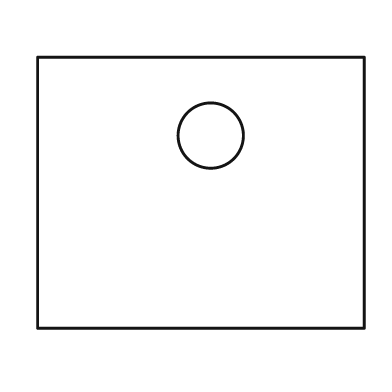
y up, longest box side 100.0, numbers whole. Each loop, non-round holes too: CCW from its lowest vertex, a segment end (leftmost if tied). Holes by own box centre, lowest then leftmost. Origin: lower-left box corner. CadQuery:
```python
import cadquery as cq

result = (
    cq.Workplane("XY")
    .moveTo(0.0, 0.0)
    .lineTo(100.0, 0.0)
    .lineTo(100.0, 83.0)
    .lineTo(0.0, 83.0)
    .close()
    .moveTo(53.0, 59.0)
    .circle(10.0)
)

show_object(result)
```